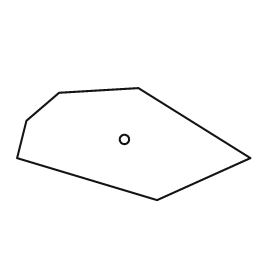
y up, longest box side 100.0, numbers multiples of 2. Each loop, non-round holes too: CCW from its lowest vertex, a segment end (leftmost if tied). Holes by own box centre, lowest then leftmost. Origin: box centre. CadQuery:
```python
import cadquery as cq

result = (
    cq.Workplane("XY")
    .moveTo(10.0, -24.0)
    .lineTo(50.0, -6.0)
    .lineTo(2.0, 24.0)
    .lineTo(-32.0, 22.0)
    .lineTo(-46.0, 10.0)
    .lineTo(-50.0, -6.0)
    .close()
    .moveTo(-4.0, 2.0)
    .circle(2.0)
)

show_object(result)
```